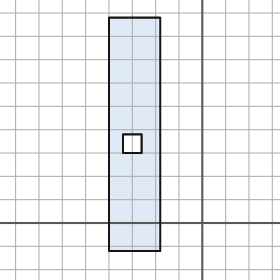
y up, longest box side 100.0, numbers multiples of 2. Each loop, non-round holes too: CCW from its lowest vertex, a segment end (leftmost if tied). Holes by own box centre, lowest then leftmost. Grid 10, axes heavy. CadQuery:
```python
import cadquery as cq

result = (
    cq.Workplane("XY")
    .moveTo(-40.0, -12.0)
    .lineTo(-18.0, -12.0)
    .lineTo(-18.0, 88.0)
    .lineTo(-40.0, 88.0)
    .close()
    .moveTo(-34.0, 30.0)
    .lineTo(-26.0, 30.0)
    .lineTo(-26.0, 38.0)
    .lineTo(-34.0, 38.0)
    .close()
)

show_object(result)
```